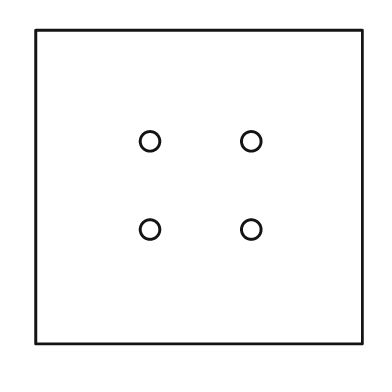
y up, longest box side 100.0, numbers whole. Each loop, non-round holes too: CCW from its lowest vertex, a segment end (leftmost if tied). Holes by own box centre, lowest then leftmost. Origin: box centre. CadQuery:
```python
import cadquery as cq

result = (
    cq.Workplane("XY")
    .moveTo(-50.0, -48.0)
    .lineTo(50.0, -48.0)
    .lineTo(50.0, 48.0)
    .lineTo(-50.0, 48.0)
    .close()
    .moveTo(-15.0, -13.0)
    .circle(3.0)
    .moveTo(16.0, -13.0)
    .circle(3.0)
    .moveTo(-15.0, 14.0)
    .circle(3.0)
    .moveTo(16.0, 14.0)
    .circle(3.0)
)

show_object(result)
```